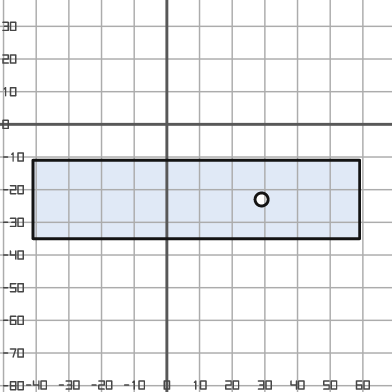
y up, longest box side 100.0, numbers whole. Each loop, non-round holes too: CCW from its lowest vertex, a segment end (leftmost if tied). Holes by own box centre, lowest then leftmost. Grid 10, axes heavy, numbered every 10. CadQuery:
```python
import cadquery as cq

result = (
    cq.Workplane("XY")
    .moveTo(-41.0, -35.0)
    .lineTo(59.0, -35.0)
    .lineTo(59.0, -11.0)
    .lineTo(-41.0, -11.0)
    .close()
    .moveTo(29.0, -23.0)
    .circle(2.0)
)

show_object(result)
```